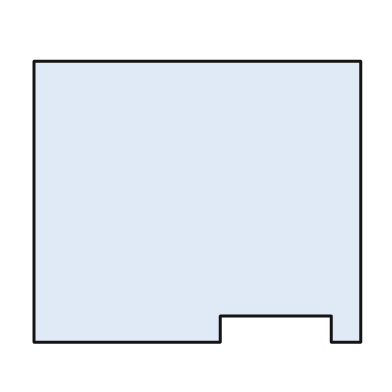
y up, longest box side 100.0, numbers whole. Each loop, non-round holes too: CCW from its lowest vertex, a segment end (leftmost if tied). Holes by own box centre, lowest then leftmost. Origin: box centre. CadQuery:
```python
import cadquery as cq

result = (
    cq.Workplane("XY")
    .moveTo(-50.0, -43.0)
    .lineTo(7.0, -43.0)
    .lineTo(7.0, -35.0)
    .lineTo(41.0, -35.0)
    .lineTo(41.0, -43.0)
    .lineTo(50.0, -43.0)
    .lineTo(50.0, 43.0)
    .lineTo(-50.0, 43.0)
    .close()
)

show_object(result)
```